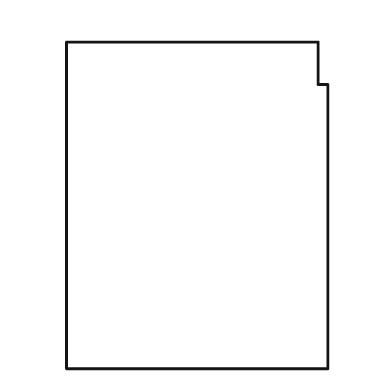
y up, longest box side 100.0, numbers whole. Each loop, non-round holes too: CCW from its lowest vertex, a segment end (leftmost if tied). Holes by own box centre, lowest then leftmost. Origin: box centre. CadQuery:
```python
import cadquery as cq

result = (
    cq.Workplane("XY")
    .moveTo(-40.0, -50.0)
    .lineTo(40.0, -50.0)
    .lineTo(40.0, 37.0)
    .lineTo(37.0, 37.0)
    .lineTo(37.0, 50.0)
    .lineTo(-40.0, 50.0)
    .close()
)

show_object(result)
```